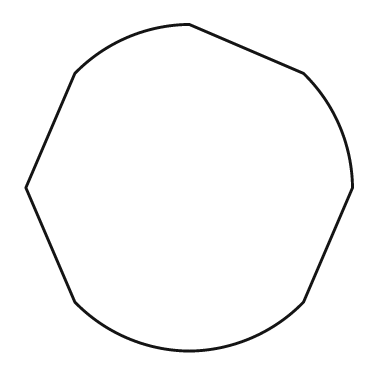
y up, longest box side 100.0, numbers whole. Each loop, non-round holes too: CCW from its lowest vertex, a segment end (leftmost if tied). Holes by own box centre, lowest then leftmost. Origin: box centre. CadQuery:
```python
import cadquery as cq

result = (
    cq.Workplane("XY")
    .moveTo(0.0, -50.0)
    .threePointArc((19.0, -46.0), (35.0, -35.0))
    .lineTo(50.0, 0.0)
    .threePointArc((46.0, 19.0), (35.0, 35.0))
    .lineTo(0.0, 50.0)
    .threePointArc((-19.0, 46.0), (-35.0, 35.0))
    .lineTo(-50.0, 0.0)
    .lineTo(-35.0, -35.0)
    .threePointArc((-19.0, -46.0), (0.0, -50.0))
    .close()
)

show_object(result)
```